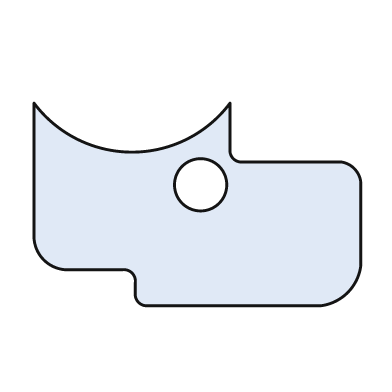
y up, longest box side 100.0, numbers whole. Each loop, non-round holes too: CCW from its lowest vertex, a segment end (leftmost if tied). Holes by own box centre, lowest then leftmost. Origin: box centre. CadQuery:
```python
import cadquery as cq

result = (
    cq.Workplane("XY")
    .moveTo(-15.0, -31.0)
    .lineTo(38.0, -31.0)
    .threePointArc((46.0, -27.0), (50.0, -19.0))
    .lineTo(50.0, 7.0)
    .threePointArc((48.0, 11.0), (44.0, 13.0))
    .lineTo(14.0, 13.0)
    .threePointArc((11.0, 14.0), (10.0, 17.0))
    .lineTo(10.0, 31.0)
    .threePointArc((-20.0, 16.0), (-50.0, 31.0))
    .lineTo(-50.0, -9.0)
    .threePointArc((-47.0, -17.0), (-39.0, -20.0))
    .lineTo(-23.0, -20.0)
    .threePointArc((-20.0, -21.0), (-19.0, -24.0))
    .lineTo(-19.0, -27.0)
    .threePointArc((-18.0, -30.0), (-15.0, -31.0))
    .close()
    .moveTo(1.0, 6.0)
    .circle(8.0)
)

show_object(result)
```